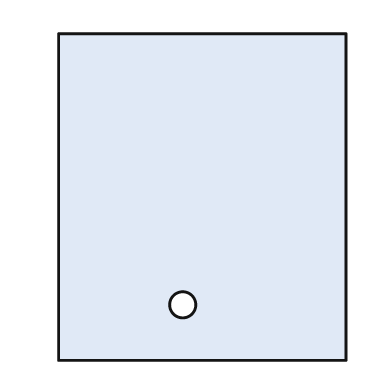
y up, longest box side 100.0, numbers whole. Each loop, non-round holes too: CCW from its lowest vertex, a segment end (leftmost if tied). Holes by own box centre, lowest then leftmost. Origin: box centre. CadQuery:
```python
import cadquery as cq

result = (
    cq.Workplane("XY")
    .moveTo(-44.0, -50.0)
    .lineTo(44.0, -50.0)
    .lineTo(44.0, 50.0)
    .lineTo(-44.0, 50.0)
    .close()
    .moveTo(-6.0, -33.0)
    .circle(4.0)
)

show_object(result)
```